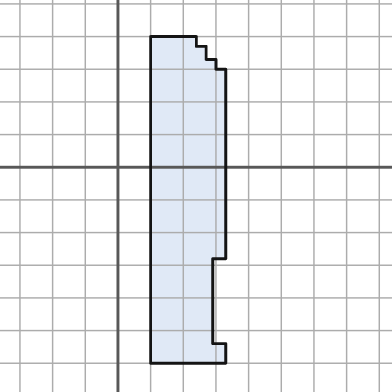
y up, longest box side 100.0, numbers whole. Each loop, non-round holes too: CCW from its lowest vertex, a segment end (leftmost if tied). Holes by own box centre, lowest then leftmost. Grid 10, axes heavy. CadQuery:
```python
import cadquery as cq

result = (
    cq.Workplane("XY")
    .moveTo(10.0, -60.0)
    .lineTo(33.0, -60.0)
    .lineTo(33.0, -54.0)
    .lineTo(29.0, -54.0)
    .lineTo(29.0, -28.0)
    .lineTo(33.0, -28.0)
    .lineTo(33.0, 30.0)
    .lineTo(30.0, 30.0)
    .lineTo(30.0, 33.0)
    .lineTo(27.0, 33.0)
    .lineTo(27.0, 37.0)
    .lineTo(24.0, 37.0)
    .lineTo(24.0, 40.0)
    .lineTo(10.0, 40.0)
    .close()
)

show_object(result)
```